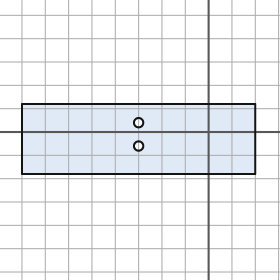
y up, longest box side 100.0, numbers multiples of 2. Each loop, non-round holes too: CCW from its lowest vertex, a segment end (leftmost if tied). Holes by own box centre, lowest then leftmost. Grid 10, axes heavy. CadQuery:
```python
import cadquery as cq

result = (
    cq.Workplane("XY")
    .moveTo(-80.0, -18.0)
    .lineTo(20.0, -18.0)
    .lineTo(20.0, 12.0)
    .lineTo(-80.0, 12.0)
    .close()
    .moveTo(-30.0, -6.0)
    .circle(2.0)
    .moveTo(-30.0, 4.0)
    .circle(2.0)
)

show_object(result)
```